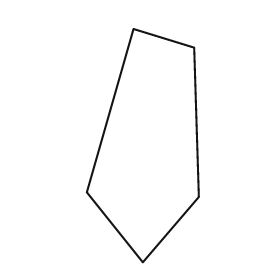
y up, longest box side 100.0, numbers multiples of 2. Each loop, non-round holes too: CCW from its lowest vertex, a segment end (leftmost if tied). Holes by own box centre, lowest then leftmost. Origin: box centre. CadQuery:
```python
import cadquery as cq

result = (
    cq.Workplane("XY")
    .moveTo(0.0, -50.0)
    .lineTo(24.0, -22.0)
    .lineTo(22.0, 42.0)
    .lineTo(-4.0, 50.0)
    .lineTo(-24.0, -20.0)
    .close()
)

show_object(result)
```